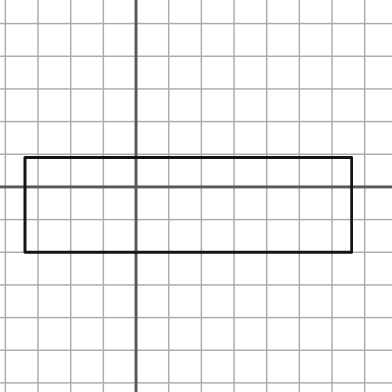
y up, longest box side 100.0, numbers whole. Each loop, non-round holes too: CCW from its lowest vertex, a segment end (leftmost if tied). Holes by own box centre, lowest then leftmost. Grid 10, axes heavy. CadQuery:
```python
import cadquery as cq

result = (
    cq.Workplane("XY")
    .moveTo(-34.0, -20.0)
    .lineTo(66.0, -20.0)
    .lineTo(66.0, 9.0)
    .lineTo(-34.0, 9.0)
    .close()
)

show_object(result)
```